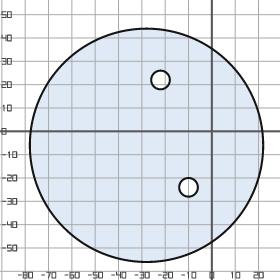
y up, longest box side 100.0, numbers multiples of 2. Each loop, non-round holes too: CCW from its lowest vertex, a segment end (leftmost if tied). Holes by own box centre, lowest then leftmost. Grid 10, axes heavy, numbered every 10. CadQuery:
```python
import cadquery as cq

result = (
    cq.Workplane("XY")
    .moveTo(-28.0, -6.0)
    .circle(50.0)
    .moveTo(-10.0, -24.0)
    .circle(4.0)
    .moveTo(-22.0, 22.0)
    .circle(4.0)
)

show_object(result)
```